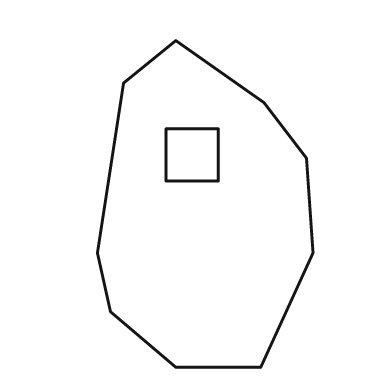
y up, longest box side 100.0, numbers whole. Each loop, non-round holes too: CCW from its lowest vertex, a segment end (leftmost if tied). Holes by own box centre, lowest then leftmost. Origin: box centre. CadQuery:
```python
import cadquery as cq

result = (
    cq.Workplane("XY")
    .moveTo(-9.0, -50.0)
    .lineTo(17.0, -50.0)
    .lineTo(33.0, -15.0)
    .lineTo(31.0, 14.0)
    .lineTo(18.0, 31.0)
    .lineTo(-9.0, 50.0)
    .lineTo(-25.0, 37.0)
    .lineTo(-33.0, -15.0)
    .lineTo(-29.0, -33.0)
    .close()
    .moveTo(-12.0, 7.0)
    .lineTo(4.0, 7.0)
    .lineTo(4.0, 23.0)
    .lineTo(-12.0, 23.0)
    .close()
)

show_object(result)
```